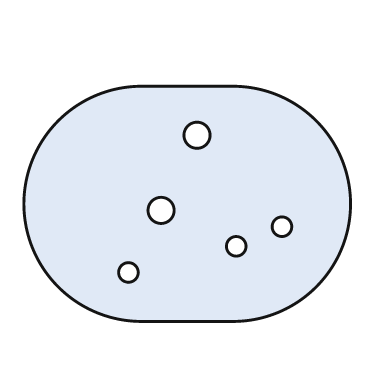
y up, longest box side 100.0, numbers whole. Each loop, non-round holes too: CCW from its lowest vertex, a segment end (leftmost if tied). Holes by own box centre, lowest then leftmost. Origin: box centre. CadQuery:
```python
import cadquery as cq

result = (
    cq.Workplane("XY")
    .moveTo(-14.0, -36.0)
    .lineTo(14.0, -36.0)
    .threePointArc((50.0, 0.0), (14.0, 36.0))
    .lineTo(-14.0, 36.0)
    .threePointArc((-50.0, 0.0), (-14.0, -36.0))
    .close()
    .moveTo(-18.0, -21.0)
    .circle(3.0)
    .moveTo(15.0, -13.0)
    .circle(3.0)
    .moveTo(29.0, -7.0)
    .circle(3.0)
    .moveTo(-8.0, -2.0)
    .circle(4.0)
    .moveTo(3.0, 21.0)
    .circle(4.0)
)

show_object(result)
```